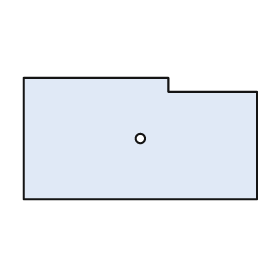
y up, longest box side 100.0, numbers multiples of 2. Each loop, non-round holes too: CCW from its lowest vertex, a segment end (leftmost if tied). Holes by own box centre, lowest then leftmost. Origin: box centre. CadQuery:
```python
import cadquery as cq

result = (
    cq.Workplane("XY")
    .moveTo(-50.0, -26.0)
    .lineTo(50.0, -26.0)
    .lineTo(50.0, 20.0)
    .lineTo(12.0, 20.0)
    .lineTo(12.0, 26.0)
    .lineTo(-50.0, 26.0)
    .close()
    .moveTo(0.0, 0.0)
    .circle(2.0)
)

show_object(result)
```